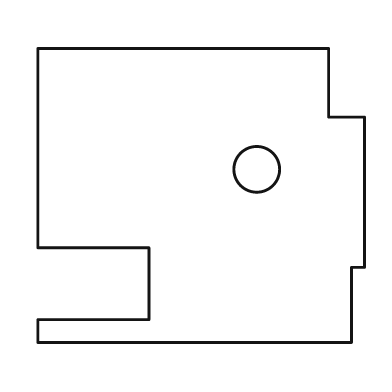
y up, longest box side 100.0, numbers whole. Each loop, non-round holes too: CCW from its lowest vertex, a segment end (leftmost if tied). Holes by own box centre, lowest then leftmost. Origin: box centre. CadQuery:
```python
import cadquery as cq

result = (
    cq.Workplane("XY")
    .moveTo(-50.0, -45.0)
    .lineTo(46.0, -45.0)
    .lineTo(46.0, -22.0)
    .lineTo(50.0, -22.0)
    .lineTo(50.0, 24.0)
    .lineTo(39.0, 24.0)
    .lineTo(39.0, 45.0)
    .lineTo(-50.0, 45.0)
    .lineTo(-50.0, -16.0)
    .lineTo(-16.0, -16.0)
    .lineTo(-16.0, -38.0)
    .lineTo(-50.0, -38.0)
    .close()
    .moveTo(17.0, 8.0)
    .circle(7.0)
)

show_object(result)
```